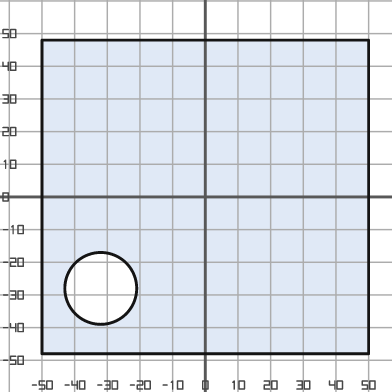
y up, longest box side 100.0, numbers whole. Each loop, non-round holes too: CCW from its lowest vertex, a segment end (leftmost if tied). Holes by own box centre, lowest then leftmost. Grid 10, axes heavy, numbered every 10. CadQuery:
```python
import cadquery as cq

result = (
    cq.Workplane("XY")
    .moveTo(-50.0, -48.0)
    .lineTo(50.0, -48.0)
    .lineTo(50.0, 48.0)
    .lineTo(-50.0, 48.0)
    .close()
    .moveTo(-32.0, -28.0)
    .circle(11.0)
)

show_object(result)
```